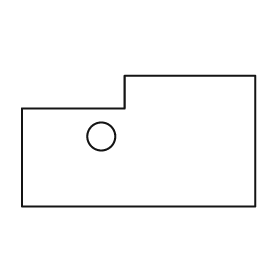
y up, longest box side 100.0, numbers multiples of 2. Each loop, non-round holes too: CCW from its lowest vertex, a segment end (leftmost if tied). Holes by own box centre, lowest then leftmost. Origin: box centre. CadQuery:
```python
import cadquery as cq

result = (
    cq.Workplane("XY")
    .moveTo(-50.0, -28.0)
    .lineTo(50.0, -28.0)
    .lineTo(50.0, 28.0)
    .lineTo(-6.0, 28.0)
    .lineTo(-6.0, 14.0)
    .lineTo(-50.0, 14.0)
    .close()
    .moveTo(-16.0, 2.0)
    .circle(6.0)
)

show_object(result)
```